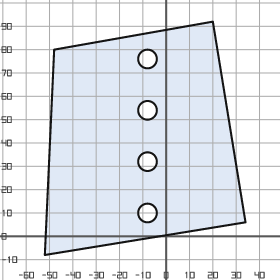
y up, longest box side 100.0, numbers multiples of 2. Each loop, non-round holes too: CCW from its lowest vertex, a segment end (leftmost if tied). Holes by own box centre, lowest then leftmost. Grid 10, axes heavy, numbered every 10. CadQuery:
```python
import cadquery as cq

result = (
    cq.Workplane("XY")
    .moveTo(-52.0, -8.0)
    .lineTo(34.0, 6.0)
    .lineTo(20.0, 92.0)
    .lineTo(-48.0, 80.0)
    .close()
    .moveTo(-8.0, 10.0)
    .circle(4.0)
    .moveTo(-8.0, 32.0)
    .circle(4.0)
    .moveTo(-8.0, 54.0)
    .circle(4.0)
    .moveTo(-8.0, 76.0)
    .circle(4.0)
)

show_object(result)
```